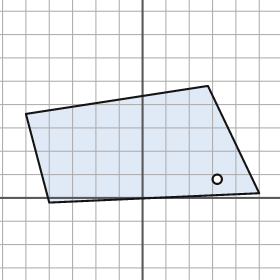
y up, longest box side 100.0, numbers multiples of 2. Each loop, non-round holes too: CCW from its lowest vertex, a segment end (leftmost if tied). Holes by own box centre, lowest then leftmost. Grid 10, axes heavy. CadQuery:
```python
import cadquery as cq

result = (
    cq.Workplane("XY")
    .moveTo(-40.0, -2.0)
    .lineTo(50.0, 2.0)
    .lineTo(28.0, 48.0)
    .lineTo(-50.0, 36.0)
    .close()
    .moveTo(32.0, 8.0)
    .circle(2.0)
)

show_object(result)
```